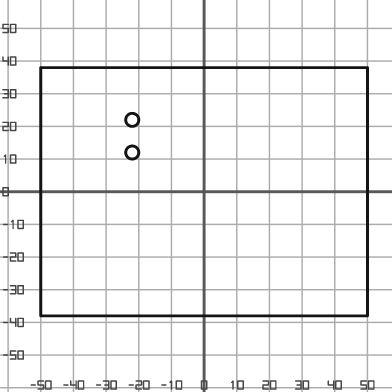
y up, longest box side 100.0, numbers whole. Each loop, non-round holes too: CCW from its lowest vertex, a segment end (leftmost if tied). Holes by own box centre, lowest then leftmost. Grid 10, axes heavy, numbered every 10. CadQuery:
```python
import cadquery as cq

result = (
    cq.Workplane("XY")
    .moveTo(-50.0, -38.0)
    .lineTo(50.0, -38.0)
    .lineTo(50.0, 38.0)
    .lineTo(-50.0, 38.0)
    .close()
    .moveTo(-22.0, 12.0)
    .circle(2.0)
    .moveTo(-22.0, 22.0)
    .circle(2.0)
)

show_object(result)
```